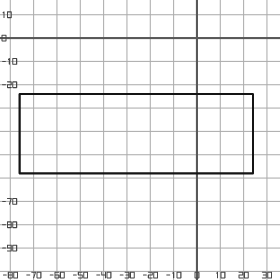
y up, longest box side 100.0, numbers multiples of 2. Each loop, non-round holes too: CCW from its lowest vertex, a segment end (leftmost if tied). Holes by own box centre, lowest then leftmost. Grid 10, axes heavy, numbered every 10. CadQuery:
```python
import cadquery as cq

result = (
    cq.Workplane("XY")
    .moveTo(-76.0, -58.0)
    .lineTo(24.0, -58.0)
    .lineTo(24.0, -24.0)
    .lineTo(-76.0, -24.0)
    .close()
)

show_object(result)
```